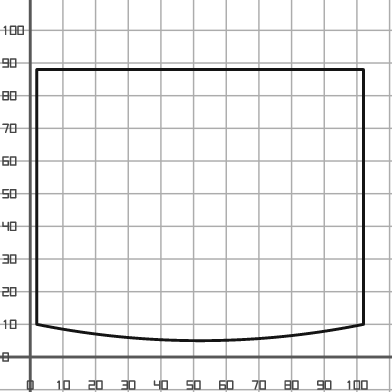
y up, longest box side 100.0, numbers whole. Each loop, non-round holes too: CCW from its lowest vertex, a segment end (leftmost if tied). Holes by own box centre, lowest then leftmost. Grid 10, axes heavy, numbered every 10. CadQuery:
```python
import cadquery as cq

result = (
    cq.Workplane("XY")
    .moveTo(2.0, 10.0)
    .threePointArc((52.0, 5.0), (102.0, 10.0))
    .lineTo(102.0, 88.0)
    .lineTo(2.0, 88.0)
    .close()
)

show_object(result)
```